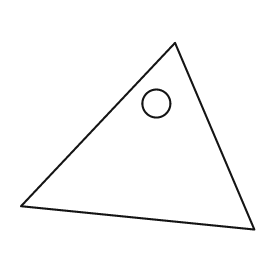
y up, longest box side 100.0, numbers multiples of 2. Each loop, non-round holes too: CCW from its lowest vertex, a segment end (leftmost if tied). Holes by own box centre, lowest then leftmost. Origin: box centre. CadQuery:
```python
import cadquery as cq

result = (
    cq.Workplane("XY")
    .moveTo(50.0, -40.0)
    .lineTo(16.0, 40.0)
    .lineTo(-50.0, -30.0)
    .close()
    .moveTo(8.0, 14.0)
    .circle(6.0)
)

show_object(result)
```